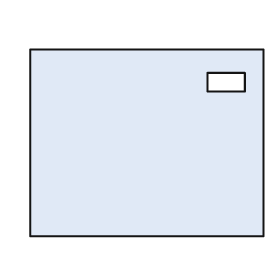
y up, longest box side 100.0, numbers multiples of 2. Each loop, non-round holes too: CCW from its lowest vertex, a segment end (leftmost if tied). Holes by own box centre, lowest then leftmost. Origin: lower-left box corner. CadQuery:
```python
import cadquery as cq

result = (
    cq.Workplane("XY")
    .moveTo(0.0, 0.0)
    .lineTo(100.0, 0.0)
    .lineTo(100.0, 80.0)
    .lineTo(0.0, 80.0)
    .close()
    .moveTo(76.0, 62.0)
    .lineTo(92.0, 62.0)
    .lineTo(92.0, 70.0)
    .lineTo(76.0, 70.0)
    .close()
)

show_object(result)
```